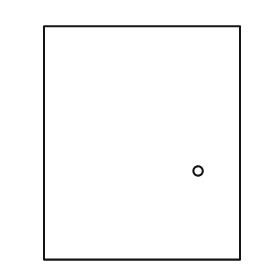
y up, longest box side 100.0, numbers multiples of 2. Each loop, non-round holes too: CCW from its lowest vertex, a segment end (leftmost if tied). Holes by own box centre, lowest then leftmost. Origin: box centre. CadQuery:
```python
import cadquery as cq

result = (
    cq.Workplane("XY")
    .moveTo(-42.0, -50.0)
    .lineTo(42.0, -50.0)
    .lineTo(42.0, 50.0)
    .lineTo(-42.0, 50.0)
    .close()
    .moveTo(24.0, -12.0)
    .circle(2.0)
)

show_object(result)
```